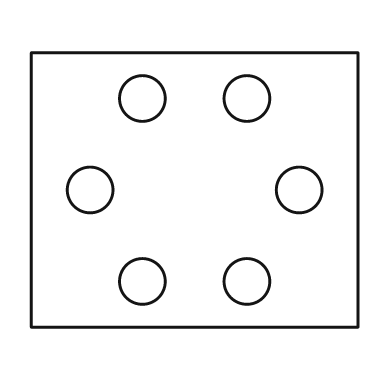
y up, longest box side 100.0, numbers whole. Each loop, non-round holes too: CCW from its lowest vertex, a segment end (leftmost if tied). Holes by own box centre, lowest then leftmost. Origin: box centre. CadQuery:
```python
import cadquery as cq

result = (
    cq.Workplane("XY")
    .moveTo(-50.0, -42.0)
    .lineTo(50.0, -42.0)
    .lineTo(50.0, 42.0)
    .lineTo(-50.0, 42.0)
    .close()
    .moveTo(-16.0, -28.0)
    .circle(7.0)
    .moveTo(16.0, -28.0)
    .circle(7.0)
    .moveTo(-32.0, 0.0)
    .circle(7.0)
    .moveTo(32.0, 0.0)
    .circle(7.0)
    .moveTo(-16.0, 28.0)
    .circle(7.0)
    .moveTo(16.0, 28.0)
    .circle(7.0)
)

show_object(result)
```